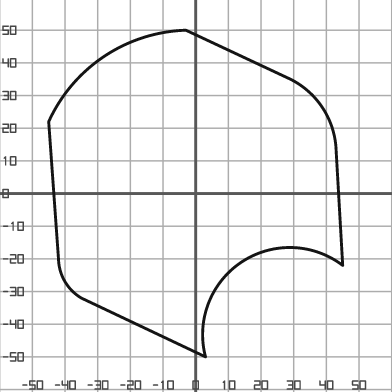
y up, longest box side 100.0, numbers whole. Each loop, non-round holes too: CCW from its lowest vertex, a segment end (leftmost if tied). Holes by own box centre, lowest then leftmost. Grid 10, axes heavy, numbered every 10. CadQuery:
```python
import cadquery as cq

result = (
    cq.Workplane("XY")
    .moveTo(3.0, -50.0)
    .threePointArc((14.0, -21.0), (45.0, -22.0))
    .lineTo(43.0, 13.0)
    .threePointArc((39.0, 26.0), (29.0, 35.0))
    .lineTo(-3.0, 50.0)
    .threePointArc((-28.0, 42.0), (-45.0, 22.0))
    .lineTo(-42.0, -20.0)
    .threePointArc((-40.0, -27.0), (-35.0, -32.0))
    .close()
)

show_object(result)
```